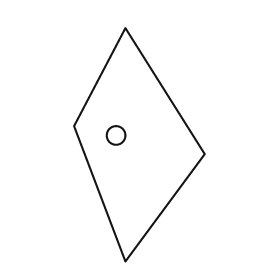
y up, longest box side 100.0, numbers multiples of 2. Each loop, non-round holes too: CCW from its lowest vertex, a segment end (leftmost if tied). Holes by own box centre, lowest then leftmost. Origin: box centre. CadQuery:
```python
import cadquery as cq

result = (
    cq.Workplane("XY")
    .moveTo(-6.0, -50.0)
    .lineTo(28.0, -4.0)
    .lineTo(-6.0, 50.0)
    .lineTo(-28.0, 8.0)
    .close()
    .moveTo(-10.0, 4.0)
    .circle(4.0)
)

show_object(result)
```